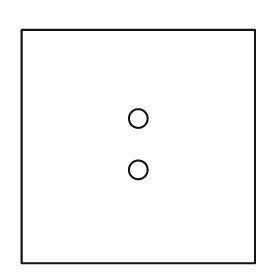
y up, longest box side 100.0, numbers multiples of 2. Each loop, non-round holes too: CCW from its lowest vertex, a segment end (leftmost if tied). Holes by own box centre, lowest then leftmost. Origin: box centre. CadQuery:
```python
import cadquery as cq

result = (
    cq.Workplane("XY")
    .moveTo(-50.0, -50.0)
    .lineTo(50.0, -50.0)
    .lineTo(50.0, 50.0)
    .lineTo(-50.0, 50.0)
    .close()
    .moveTo(0.0, -10.0)
    .circle(4.0)
    .moveTo(0.0, 12.0)
    .circle(4.0)
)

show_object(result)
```